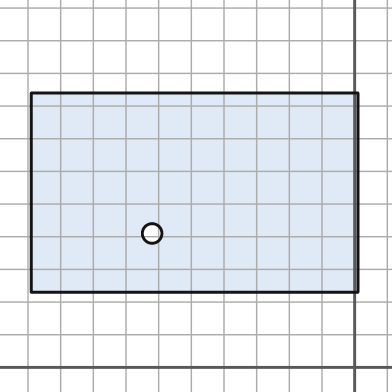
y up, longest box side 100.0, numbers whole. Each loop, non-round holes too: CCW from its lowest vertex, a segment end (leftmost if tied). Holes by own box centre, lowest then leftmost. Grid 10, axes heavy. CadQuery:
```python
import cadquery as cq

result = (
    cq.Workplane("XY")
    .moveTo(-99.0, 23.0)
    .lineTo(1.0, 23.0)
    .lineTo(1.0, 84.0)
    .lineTo(-99.0, 84.0)
    .close()
    .moveTo(-62.0, 41.0)
    .circle(3.0)
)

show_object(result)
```